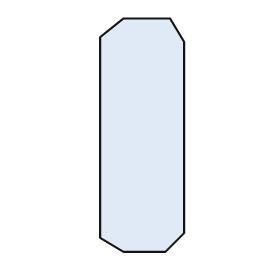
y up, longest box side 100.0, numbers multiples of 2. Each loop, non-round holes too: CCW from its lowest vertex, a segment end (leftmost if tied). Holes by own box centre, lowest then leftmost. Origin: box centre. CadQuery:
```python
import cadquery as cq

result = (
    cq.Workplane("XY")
    .moveTo(-8.0, -50.0)
    .lineTo(10.0, -50.0)
    .lineTo(18.0, -42.0)
    .lineTo(18.0, 40.0)
    .lineTo(12.0, 50.0)
    .lineTo(-8.0, 50.0)
    .lineTo(-18.0, 42.0)
    .lineTo(-18.0, -44.0)
    .close()
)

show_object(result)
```